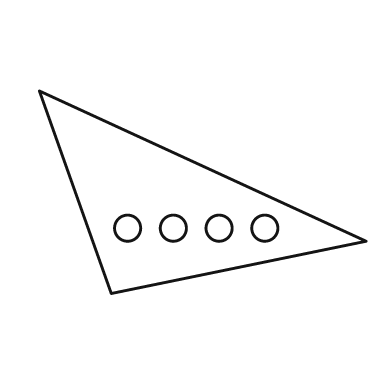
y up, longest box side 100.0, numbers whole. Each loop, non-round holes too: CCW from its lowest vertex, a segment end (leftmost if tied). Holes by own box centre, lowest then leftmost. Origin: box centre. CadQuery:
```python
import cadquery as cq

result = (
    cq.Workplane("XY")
    .moveTo(-28.0, -31.0)
    .lineTo(50.0, -15.0)
    .lineTo(-50.0, 31.0)
    .close()
    .moveTo(-23.0, -11.0)
    .circle(4.0)
    .moveTo(-9.0, -11.0)
    .circle(4.0)
    .moveTo(5.0, -11.0)
    .circle(4.0)
    .moveTo(19.0, -11.0)
    .circle(4.0)
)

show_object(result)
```